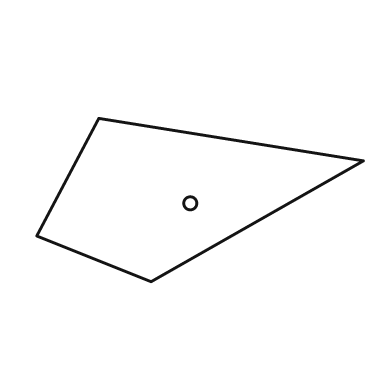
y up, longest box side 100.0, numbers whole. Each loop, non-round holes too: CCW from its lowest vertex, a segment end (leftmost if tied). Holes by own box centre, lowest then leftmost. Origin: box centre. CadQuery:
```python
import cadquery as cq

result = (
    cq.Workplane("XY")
    .moveTo(-15.0, -25.0)
    .lineTo(50.0, 12.0)
    .lineTo(-31.0, 25.0)
    .lineTo(-50.0, -11.0)
    .close()
    .moveTo(-3.0, -1.0)
    .circle(2.0)
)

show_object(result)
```